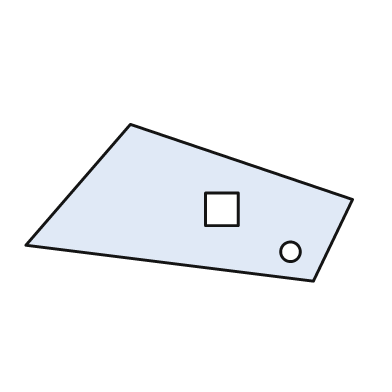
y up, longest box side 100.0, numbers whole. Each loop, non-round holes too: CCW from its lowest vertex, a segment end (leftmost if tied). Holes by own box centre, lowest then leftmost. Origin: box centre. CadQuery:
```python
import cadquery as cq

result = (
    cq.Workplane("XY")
    .moveTo(38.0, -24.0)
    .lineTo(50.0, 1.0)
    .lineTo(-18.0, 24.0)
    .lineTo(-50.0, -13.0)
    .close()
    .moveTo(31.0, -15.0)
    .circle(3.0)
    .moveTo(5.0, -7.0)
    .lineTo(15.0, -7.0)
    .lineTo(15.0, 3.0)
    .lineTo(5.0, 3.0)
    .close()
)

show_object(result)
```